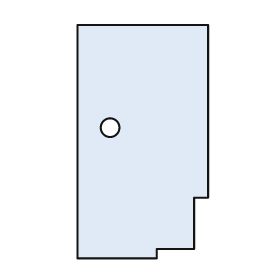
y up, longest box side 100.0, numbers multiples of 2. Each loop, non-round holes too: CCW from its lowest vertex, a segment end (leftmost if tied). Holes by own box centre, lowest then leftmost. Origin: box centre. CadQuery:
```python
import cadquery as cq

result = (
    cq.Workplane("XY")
    .moveTo(-28.0, -50.0)
    .lineTo(6.0, -50.0)
    .lineTo(6.0, -46.0)
    .lineTo(22.0, -46.0)
    .lineTo(22.0, -24.0)
    .lineTo(28.0, -24.0)
    .lineTo(28.0, 50.0)
    .lineTo(-28.0, 50.0)
    .close()
    .moveTo(-14.0, 6.0)
    .circle(4.0)
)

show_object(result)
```